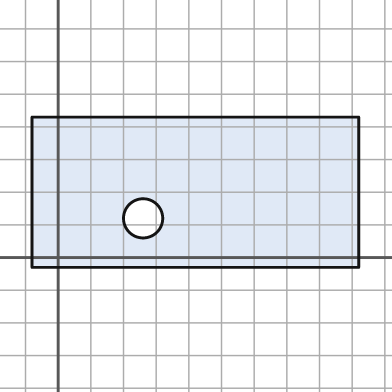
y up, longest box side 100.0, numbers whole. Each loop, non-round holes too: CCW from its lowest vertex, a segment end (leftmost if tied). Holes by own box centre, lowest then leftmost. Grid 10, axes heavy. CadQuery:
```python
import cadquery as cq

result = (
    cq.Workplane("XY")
    .moveTo(-8.0, -3.0)
    .lineTo(92.0, -3.0)
    .lineTo(92.0, 43.0)
    .lineTo(-8.0, 43.0)
    .close()
    .moveTo(26.0, 12.0)
    .circle(6.0)
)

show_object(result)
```